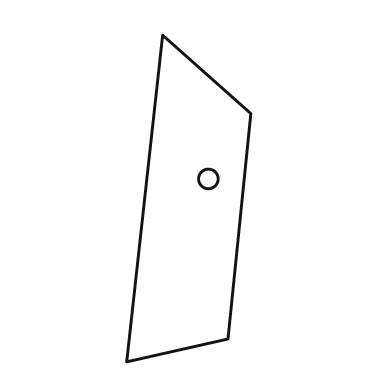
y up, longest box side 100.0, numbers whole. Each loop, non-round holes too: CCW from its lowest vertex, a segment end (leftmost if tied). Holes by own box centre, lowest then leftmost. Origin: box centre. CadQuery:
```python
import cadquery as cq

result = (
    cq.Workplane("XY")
    .moveTo(-19.0, -50.0)
    .lineTo(12.0, -43.0)
    .lineTo(19.0, 26.0)
    .lineTo(-8.0, 50.0)
    .close()
    .moveTo(6.0, 6.0)
    .circle(3.0)
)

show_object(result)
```